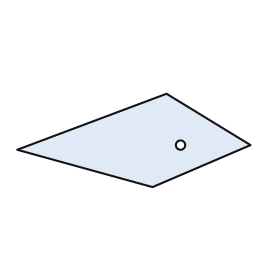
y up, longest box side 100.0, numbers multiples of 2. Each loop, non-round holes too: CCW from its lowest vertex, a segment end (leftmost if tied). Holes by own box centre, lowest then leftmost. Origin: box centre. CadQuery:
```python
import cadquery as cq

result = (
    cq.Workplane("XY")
    .moveTo(8.0, -20.0)
    .lineTo(50.0, -2.0)
    .lineTo(14.0, 20.0)
    .lineTo(-50.0, -4.0)
    .close()
    .moveTo(20.0, -2.0)
    .circle(2.0)
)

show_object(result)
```